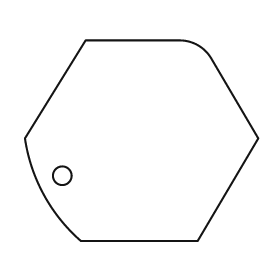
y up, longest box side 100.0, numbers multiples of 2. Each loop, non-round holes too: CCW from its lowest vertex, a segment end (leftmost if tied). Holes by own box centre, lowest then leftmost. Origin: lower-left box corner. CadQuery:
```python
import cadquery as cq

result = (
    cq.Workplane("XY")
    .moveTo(24.0, 0.0)
    .lineTo(74.0, 0.0)
    .lineTo(100.0, 44.0)
    .lineTo(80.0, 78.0)
    .threePointArc((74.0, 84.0), (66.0, 86.0))
    .lineTo(26.0, 86.0)
    .lineTo(0.0, 44.0)
    .threePointArc((8.0, 20.0), (24.0, 0.0))
    .close()
    .moveTo(16.0, 28.0)
    .circle(4.0)
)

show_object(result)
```